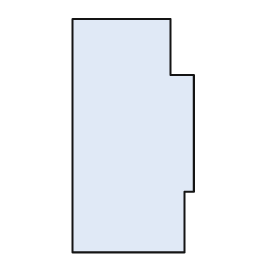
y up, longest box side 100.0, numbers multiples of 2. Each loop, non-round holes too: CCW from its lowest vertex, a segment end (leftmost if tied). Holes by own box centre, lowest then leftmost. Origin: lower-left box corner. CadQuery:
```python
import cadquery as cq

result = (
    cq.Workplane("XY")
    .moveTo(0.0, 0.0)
    .lineTo(48.0, 0.0)
    .lineTo(48.0, 26.0)
    .lineTo(52.0, 26.0)
    .lineTo(52.0, 76.0)
    .lineTo(42.0, 76.0)
    .lineTo(42.0, 100.0)
    .lineTo(0.0, 100.0)
    .close()
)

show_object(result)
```